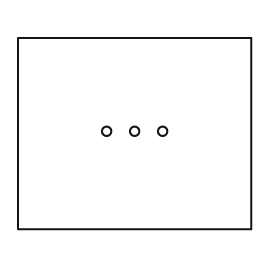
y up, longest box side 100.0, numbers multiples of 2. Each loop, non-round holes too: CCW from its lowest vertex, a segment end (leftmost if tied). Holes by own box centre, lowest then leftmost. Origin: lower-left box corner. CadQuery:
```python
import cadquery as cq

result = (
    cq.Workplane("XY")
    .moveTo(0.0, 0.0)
    .lineTo(100.0, 0.0)
    .lineTo(100.0, 82.0)
    .lineTo(0.0, 82.0)
    .close()
    .moveTo(38.0, 42.0)
    .circle(2.0)
    .moveTo(50.0, 42.0)
    .circle(2.0)
    .moveTo(62.0, 42.0)
    .circle(2.0)
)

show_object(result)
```